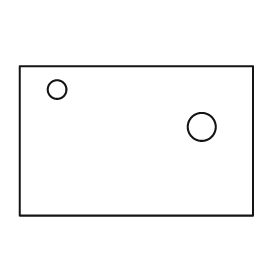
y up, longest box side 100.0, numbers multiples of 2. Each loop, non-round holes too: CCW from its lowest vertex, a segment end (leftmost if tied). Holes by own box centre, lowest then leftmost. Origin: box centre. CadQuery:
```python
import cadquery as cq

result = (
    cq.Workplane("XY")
    .moveTo(-50.0, -32.0)
    .lineTo(50.0, -32.0)
    .lineTo(50.0, 32.0)
    .lineTo(-50.0, 32.0)
    .close()
    .moveTo(28.0, 6.0)
    .circle(6.0)
    .moveTo(-34.0, 22.0)
    .circle(4.0)
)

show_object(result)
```